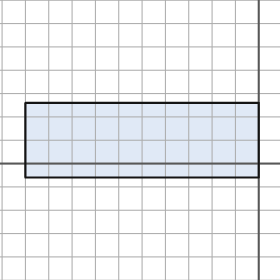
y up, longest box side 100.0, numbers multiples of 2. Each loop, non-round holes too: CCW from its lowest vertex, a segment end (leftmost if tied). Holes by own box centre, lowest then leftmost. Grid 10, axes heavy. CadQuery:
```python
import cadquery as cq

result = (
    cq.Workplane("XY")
    .moveTo(-100.0, -6.0)
    .lineTo(0.0, -6.0)
    .lineTo(0.0, 26.0)
    .lineTo(-100.0, 26.0)
    .close()
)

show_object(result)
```